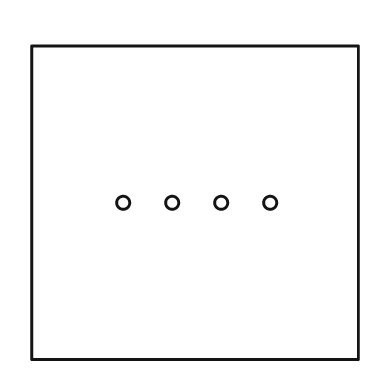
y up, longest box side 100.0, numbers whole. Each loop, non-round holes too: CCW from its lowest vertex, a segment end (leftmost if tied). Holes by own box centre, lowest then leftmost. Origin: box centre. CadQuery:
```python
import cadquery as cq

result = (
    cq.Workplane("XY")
    .moveTo(-50.0, -48.0)
    .lineTo(50.0, -48.0)
    .lineTo(50.0, 48.0)
    .lineTo(-50.0, 48.0)
    .close()
    .moveTo(-22.0, 0.0)
    .circle(2.0)
    .moveTo(-7.0, 0.0)
    .circle(2.0)
    .moveTo(8.0, 0.0)
    .circle(2.0)
    .moveTo(23.0, 0.0)
    .circle(2.0)
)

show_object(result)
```